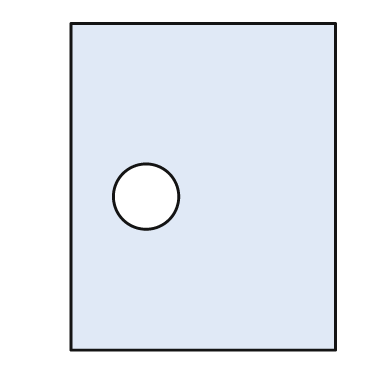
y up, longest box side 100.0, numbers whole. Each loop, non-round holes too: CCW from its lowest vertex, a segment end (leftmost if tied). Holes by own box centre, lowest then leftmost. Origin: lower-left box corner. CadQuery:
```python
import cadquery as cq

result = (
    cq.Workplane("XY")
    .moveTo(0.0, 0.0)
    .lineTo(81.0, 0.0)
    .lineTo(81.0, 100.0)
    .lineTo(0.0, 100.0)
    .close()
    .moveTo(23.0, 47.0)
    .circle(10.0)
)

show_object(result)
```